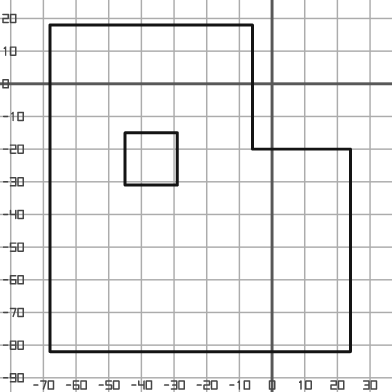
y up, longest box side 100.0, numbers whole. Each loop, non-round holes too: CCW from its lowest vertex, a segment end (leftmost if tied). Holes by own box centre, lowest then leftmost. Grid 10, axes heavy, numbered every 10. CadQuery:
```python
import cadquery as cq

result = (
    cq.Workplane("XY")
    .moveTo(-68.0, -82.0)
    .lineTo(24.0, -82.0)
    .lineTo(24.0, -20.0)
    .lineTo(-6.0, -20.0)
    .lineTo(-6.0, 18.0)
    .lineTo(-68.0, 18.0)
    .close()
    .moveTo(-45.0, -31.0)
    .lineTo(-29.0, -31.0)
    .lineTo(-29.0, -15.0)
    .lineTo(-45.0, -15.0)
    .close()
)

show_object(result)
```